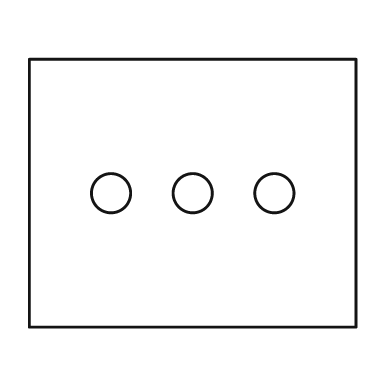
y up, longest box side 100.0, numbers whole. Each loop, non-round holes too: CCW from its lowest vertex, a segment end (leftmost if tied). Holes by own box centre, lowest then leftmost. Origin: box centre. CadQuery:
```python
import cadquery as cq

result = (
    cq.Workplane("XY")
    .moveTo(-50.0, -41.0)
    .lineTo(50.0, -41.0)
    .lineTo(50.0, 41.0)
    .lineTo(-50.0, 41.0)
    .close()
    .moveTo(-25.0, 0.0)
    .circle(6.0)
    .moveTo(0.0, 0.0)
    .circle(6.0)
    .moveTo(25.0, 0.0)
    .circle(6.0)
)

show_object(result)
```